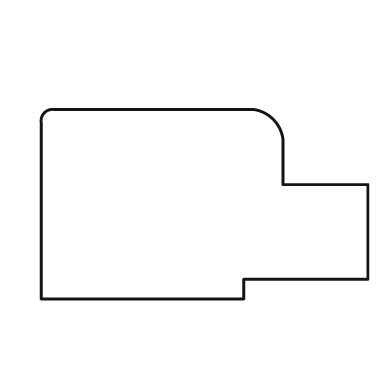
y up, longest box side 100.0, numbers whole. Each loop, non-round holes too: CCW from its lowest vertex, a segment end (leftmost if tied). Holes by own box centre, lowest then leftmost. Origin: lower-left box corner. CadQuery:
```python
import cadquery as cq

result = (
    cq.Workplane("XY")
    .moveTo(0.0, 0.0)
    .lineTo(62.0, 0.0)
    .lineTo(62.0, 6.0)
    .lineTo(100.0, 6.0)
    .lineTo(100.0, 35.0)
    .lineTo(74.0, 35.0)
    .lineTo(74.0, 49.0)
    .threePointArc((71.0, 55.0), (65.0, 58.0))
    .lineTo(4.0, 58.0)
    .threePointArc((1.0, 57.0), (0.0, 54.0))
    .close()
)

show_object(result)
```